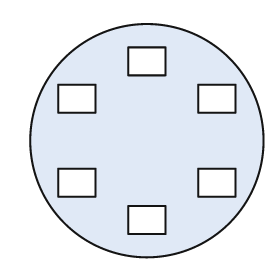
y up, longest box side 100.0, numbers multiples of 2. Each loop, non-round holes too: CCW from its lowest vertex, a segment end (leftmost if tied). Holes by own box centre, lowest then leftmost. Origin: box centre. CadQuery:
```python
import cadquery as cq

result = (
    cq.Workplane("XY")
    .moveTo(0.0, 0.0)
    .circle(50.0)
    .moveTo(-8.0, -40.0)
    .lineTo(8.0, -40.0)
    .lineTo(8.0, -28.0)
    .lineTo(-8.0, -28.0)
    .close()
    .moveTo(-38.0, -24.0)
    .lineTo(-22.0, -24.0)
    .lineTo(-22.0, -12.0)
    .lineTo(-38.0, -12.0)
    .close()
    .moveTo(22.0, -24.0)
    .lineTo(38.0, -24.0)
    .lineTo(38.0, -12.0)
    .lineTo(22.0, -12.0)
    .close()
    .moveTo(-38.0, 12.0)
    .lineTo(-22.0, 12.0)
    .lineTo(-22.0, 24.0)
    .lineTo(-38.0, 24.0)
    .close()
    .moveTo(22.0, 12.0)
    .lineTo(38.0, 12.0)
    .lineTo(38.0, 24.0)
    .lineTo(22.0, 24.0)
    .close()
    .moveTo(-8.0, 28.0)
    .lineTo(8.0, 28.0)
    .lineTo(8.0, 40.0)
    .lineTo(-8.0, 40.0)
    .close()
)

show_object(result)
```